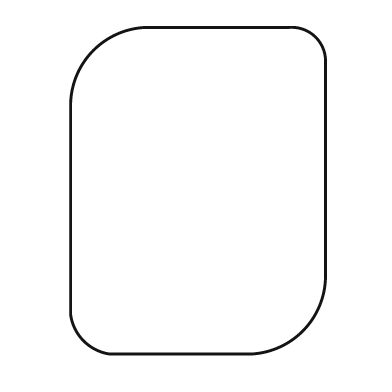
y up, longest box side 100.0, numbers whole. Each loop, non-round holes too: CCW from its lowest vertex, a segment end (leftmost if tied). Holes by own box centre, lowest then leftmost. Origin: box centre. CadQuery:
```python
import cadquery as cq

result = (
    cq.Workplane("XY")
    .moveTo(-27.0, -50.0)
    .lineTo(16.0, -50.0)
    .threePointArc((32.0, -43.0), (39.0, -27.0))
    .lineTo(39.0, 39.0)
    .threePointArc((36.0, 47.0), (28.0, 50.0))
    .lineTo(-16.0, 50.0)
    .threePointArc((-32.0, 43.0), (-39.0, 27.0))
    .lineTo(-39.0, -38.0)
    .threePointArc((-35.0, -46.0), (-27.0, -50.0))
    .close()
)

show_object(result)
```